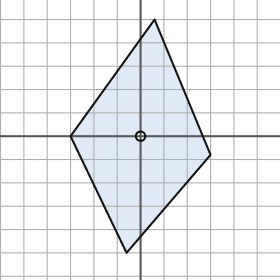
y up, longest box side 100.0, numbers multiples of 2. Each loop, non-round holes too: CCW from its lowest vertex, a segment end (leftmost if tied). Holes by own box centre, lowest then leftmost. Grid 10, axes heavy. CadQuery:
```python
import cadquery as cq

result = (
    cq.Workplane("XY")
    .moveTo(-6.0, -50.0)
    .lineTo(30.0, -8.0)
    .lineTo(6.0, 50.0)
    .lineTo(-30.0, 0.0)
    .close()
    .moveTo(0.0, 0.0)
    .circle(2.0)
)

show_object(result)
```